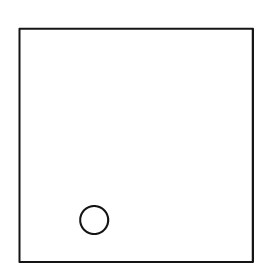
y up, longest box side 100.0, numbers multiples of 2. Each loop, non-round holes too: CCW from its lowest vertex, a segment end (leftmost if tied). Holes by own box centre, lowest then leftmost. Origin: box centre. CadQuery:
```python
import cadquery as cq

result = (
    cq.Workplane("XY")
    .moveTo(-50.0, -50.0)
    .lineTo(50.0, -50.0)
    .lineTo(50.0, 50.0)
    .lineTo(-50.0, 50.0)
    .close()
    .moveTo(-18.0, -32.0)
    .circle(6.0)
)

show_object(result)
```